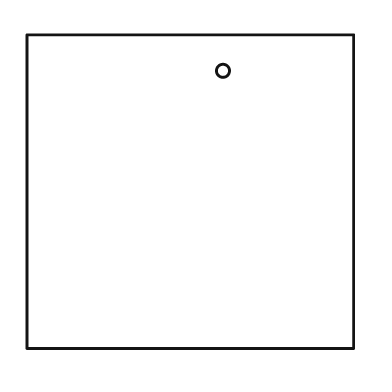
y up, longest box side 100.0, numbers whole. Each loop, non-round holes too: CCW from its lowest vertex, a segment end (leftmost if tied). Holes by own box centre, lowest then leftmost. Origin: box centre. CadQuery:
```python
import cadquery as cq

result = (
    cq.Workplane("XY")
    .moveTo(-50.0, -48.0)
    .lineTo(50.0, -48.0)
    .lineTo(50.0, 48.0)
    .lineTo(-50.0, 48.0)
    .close()
    .moveTo(10.0, 37.0)
    .circle(2.0)
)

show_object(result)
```